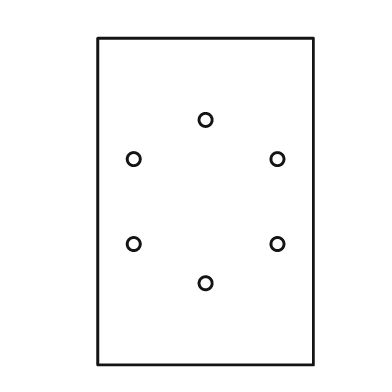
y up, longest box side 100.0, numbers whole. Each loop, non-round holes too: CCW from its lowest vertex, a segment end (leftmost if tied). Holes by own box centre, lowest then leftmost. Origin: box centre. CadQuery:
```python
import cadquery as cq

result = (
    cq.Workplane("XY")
    .moveTo(-33.0, -50.0)
    .lineTo(33.0, -50.0)
    .lineTo(33.0, 50.0)
    .lineTo(-33.0, 50.0)
    .close()
    .moveTo(0.0, -25.0)
    .circle(2.0)
    .moveTo(-22.0, -13.0)
    .circle(2.0)
    .moveTo(22.0, -13.0)
    .circle(2.0)
    .moveTo(-22.0, 13.0)
    .circle(2.0)
    .moveTo(22.0, 13.0)
    .circle(2.0)
    .moveTo(0.0, 25.0)
    .circle(2.0)
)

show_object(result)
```